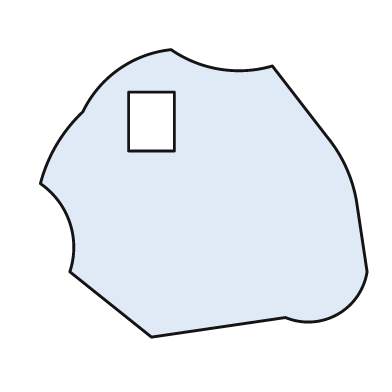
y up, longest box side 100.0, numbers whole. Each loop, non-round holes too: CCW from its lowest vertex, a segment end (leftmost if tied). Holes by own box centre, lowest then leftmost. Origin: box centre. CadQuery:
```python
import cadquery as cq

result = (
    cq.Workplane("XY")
    .moveTo(-16.0, -44.0)
    .lineTo(25.0, -38.0)
    .threePointArc((41.0, -37.0), (50.0, -24.0))
    .lineTo(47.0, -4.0)
    .threePointArc((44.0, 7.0), (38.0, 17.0))
    .lineTo(21.0, 39.0)
    .threePointArc((5.0, 38.0), (-10.0, 44.0))
    .threePointArc((-26.0, 38.0), (-37.0, 25.0))
    .threePointArc((-45.0, 15.0), (-50.0, 3.0))
    .threePointArc((-41.0, -9.0), (-41.0, -24.0))
    .close()
    .moveTo(-23.0, 13.0)
    .lineTo(-9.0, 13.0)
    .lineTo(-9.0, 31.0)
    .lineTo(-23.0, 31.0)
    .close()
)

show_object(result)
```